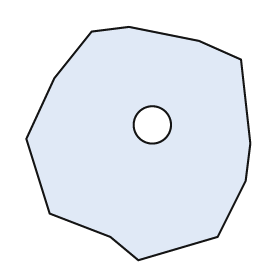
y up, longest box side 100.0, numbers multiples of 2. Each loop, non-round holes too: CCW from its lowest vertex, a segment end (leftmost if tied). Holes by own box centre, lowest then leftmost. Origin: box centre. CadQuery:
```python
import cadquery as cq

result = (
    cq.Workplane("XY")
    .moveTo(0.0, -50.0)
    .lineTo(34.0, -40.0)
    .lineTo(46.0, -16.0)
    .lineTo(48.0, 0.0)
    .lineTo(44.0, 36.0)
    .lineTo(26.0, 44.0)
    .lineTo(-4.0, 50.0)
    .lineTo(-20.0, 48.0)
    .lineTo(-36.0, 28.0)
    .lineTo(-48.0, 2.0)
    .lineTo(-38.0, -30.0)
    .lineTo(-12.0, -40.0)
    .close()
    .moveTo(6.0, 8.0)
    .circle(8.0)
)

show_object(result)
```